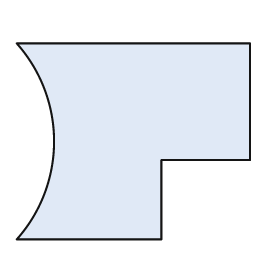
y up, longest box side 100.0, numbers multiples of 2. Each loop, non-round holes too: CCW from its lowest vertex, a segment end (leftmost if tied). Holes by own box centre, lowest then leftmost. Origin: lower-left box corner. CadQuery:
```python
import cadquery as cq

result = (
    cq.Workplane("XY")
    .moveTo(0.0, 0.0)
    .lineTo(62.0, 0.0)
    .lineTo(62.0, 34.0)
    .lineTo(100.0, 34.0)
    .lineTo(100.0, 84.0)
    .lineTo(0.0, 84.0)
    .threePointArc((16.0, 42.0), (0.0, 0.0))
    .close()
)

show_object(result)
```